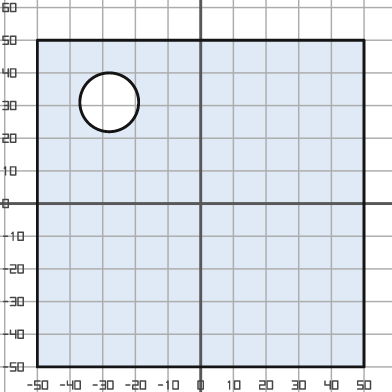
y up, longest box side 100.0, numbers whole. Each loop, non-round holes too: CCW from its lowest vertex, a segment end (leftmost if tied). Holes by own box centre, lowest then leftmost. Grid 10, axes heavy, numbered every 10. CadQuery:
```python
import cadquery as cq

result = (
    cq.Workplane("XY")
    .moveTo(-50.0, -50.0)
    .lineTo(50.0, -50.0)
    .lineTo(50.0, 50.0)
    .lineTo(-50.0, 50.0)
    .close()
    .moveTo(-28.0, 31.0)
    .circle(9.0)
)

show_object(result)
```